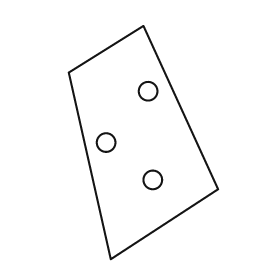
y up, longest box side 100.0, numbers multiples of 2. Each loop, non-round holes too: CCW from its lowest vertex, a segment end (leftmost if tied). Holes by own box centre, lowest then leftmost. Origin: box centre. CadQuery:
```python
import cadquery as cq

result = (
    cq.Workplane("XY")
    .moveTo(-14.0, -50.0)
    .lineTo(32.0, -20.0)
    .lineTo(0.0, 50.0)
    .lineTo(-32.0, 30.0)
    .close()
    .moveTo(4.0, -16.0)
    .circle(4.0)
    .moveTo(-16.0, 0.0)
    .circle(4.0)
    .moveTo(2.0, 22.0)
    .circle(4.0)
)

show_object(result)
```